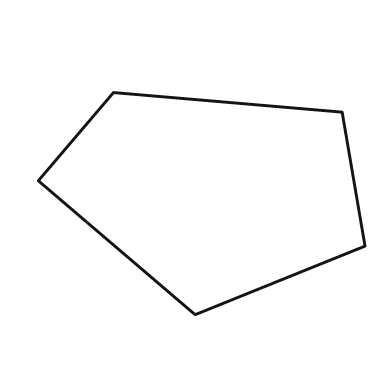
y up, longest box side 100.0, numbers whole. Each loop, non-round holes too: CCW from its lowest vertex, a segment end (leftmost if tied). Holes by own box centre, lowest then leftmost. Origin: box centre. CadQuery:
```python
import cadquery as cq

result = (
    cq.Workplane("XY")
    .moveTo(-2.0, -34.0)
    .lineTo(50.0, -13.0)
    .lineTo(43.0, 28.0)
    .lineTo(-27.0, 34.0)
    .lineTo(-50.0, 7.0)
    .close()
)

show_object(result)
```